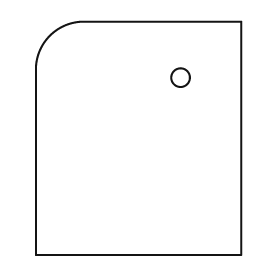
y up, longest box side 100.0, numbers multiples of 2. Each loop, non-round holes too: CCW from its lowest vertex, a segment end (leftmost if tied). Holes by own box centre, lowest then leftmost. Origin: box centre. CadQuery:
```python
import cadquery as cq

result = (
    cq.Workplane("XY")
    .moveTo(-44.0, -50.0)
    .lineTo(44.0, -50.0)
    .lineTo(44.0, 50.0)
    .lineTo(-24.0, 50.0)
    .threePointArc((-38.0, 44.0), (-44.0, 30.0))
    .close()
    .moveTo(18.0, 26.0)
    .circle(4.0)
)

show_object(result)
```